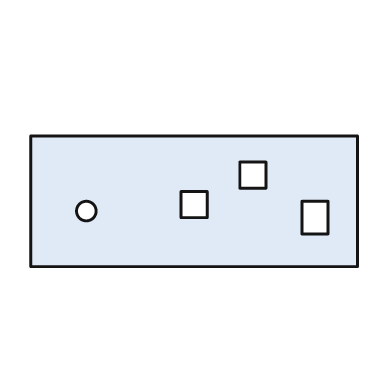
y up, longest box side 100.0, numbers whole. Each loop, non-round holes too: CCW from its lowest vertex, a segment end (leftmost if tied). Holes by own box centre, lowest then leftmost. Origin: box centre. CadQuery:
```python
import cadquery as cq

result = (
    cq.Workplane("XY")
    .moveTo(-50.0, -20.0)
    .lineTo(50.0, -20.0)
    .lineTo(50.0, 20.0)
    .lineTo(-50.0, 20.0)
    .close()
    .moveTo(33.0, -10.0)
    .lineTo(41.0, -10.0)
    .lineTo(41.0, 0.0)
    .lineTo(33.0, 0.0)
    .close()
    .moveTo(-33.0, -3.0)
    .circle(3.0)
    .moveTo(-4.0, -5.0)
    .lineTo(4.0, -5.0)
    .lineTo(4.0, 3.0)
    .lineTo(-4.0, 3.0)
    .close()
    .moveTo(14.0, 4.0)
    .lineTo(22.0, 4.0)
    .lineTo(22.0, 12.0)
    .lineTo(14.0, 12.0)
    .close()
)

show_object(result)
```